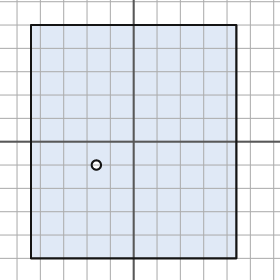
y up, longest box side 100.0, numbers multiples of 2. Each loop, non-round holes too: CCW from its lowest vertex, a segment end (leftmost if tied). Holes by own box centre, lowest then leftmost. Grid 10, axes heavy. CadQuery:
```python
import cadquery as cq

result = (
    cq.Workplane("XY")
    .moveTo(-44.0, -50.0)
    .lineTo(44.0, -50.0)
    .lineTo(44.0, 50.0)
    .lineTo(-44.0, 50.0)
    .close()
    .moveTo(-16.0, -10.0)
    .circle(2.0)
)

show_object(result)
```